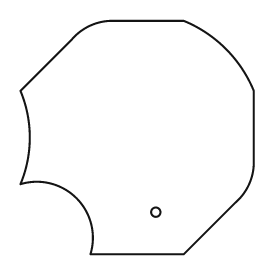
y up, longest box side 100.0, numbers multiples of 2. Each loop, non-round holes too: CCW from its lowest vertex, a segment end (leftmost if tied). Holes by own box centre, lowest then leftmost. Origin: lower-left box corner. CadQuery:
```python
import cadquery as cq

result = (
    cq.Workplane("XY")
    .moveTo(30.0, 0.0)
    .lineTo(70.0, 0.0)
    .lineTo(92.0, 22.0)
    .threePointArc((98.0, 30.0), (100.0, 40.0))
    .lineTo(100.0, 70.0)
    .threePointArc((88.0, 88.0), (70.0, 100.0))
    .lineTo(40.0, 100.0)
    .threePointArc((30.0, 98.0), (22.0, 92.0))
    .lineTo(0.0, 70.0)
    .threePointArc((4.0, 50.0), (0.0, 30.0))
    .threePointArc((24.0, 24.0), (30.0, 0.0))
    .close()
    .moveTo(58.0, 18.0)
    .circle(2.0)
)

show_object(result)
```